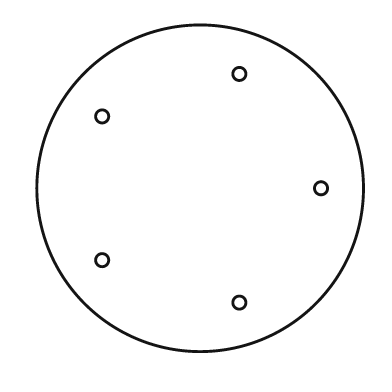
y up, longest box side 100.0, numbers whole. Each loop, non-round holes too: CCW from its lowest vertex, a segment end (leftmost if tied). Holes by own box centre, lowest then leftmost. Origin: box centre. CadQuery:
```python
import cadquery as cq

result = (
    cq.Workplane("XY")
    .moveTo(0.0, 0.0)
    .circle(50.0)
    .moveTo(12.0, -35.0)
    .circle(2.0)
    .moveTo(-30.0, -22.0)
    .circle(2.0)
    .moveTo(37.0, 0.0)
    .circle(2.0)
    .moveTo(-30.0, 22.0)
    .circle(2.0)
    .moveTo(12.0, 35.0)
    .circle(2.0)
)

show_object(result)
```